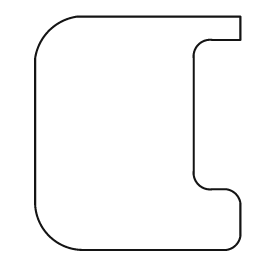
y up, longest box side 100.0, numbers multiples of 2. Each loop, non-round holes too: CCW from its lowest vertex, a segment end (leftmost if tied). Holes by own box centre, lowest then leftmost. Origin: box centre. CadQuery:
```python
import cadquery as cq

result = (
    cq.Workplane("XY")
    .moveTo(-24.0, -50.0)
    .lineTo(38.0, -50.0)
    .threePointArc((42.0, -48.0), (44.0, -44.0))
    .lineTo(44.0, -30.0)
    .threePointArc((42.0, -26.0), (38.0, -24.0))
    .lineTo(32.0, -24.0)
    .threePointArc((26.0, -22.0), (24.0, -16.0))
    .lineTo(24.0, 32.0)
    .threePointArc((26.0, 38.0), (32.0, 40.0))
    .lineTo(44.0, 40.0)
    .lineTo(44.0, 50.0)
    .lineTo(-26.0, 50.0)
    .threePointArc((-38.0, 44.0), (-44.0, 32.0))
    .lineTo(-44.0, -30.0)
    .threePointArc((-38.0, -44.0), (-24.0, -50.0))
    .close()
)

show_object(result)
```